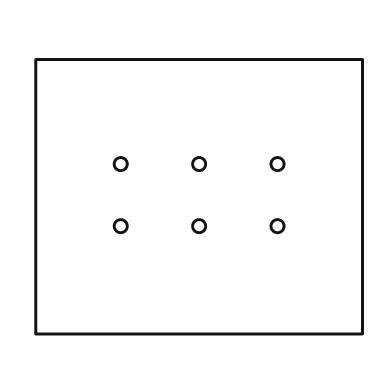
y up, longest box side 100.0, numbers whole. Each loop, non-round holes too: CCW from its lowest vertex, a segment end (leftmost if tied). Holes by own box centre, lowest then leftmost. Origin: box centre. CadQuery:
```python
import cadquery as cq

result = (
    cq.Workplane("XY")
    .moveTo(-50.0, -42.0)
    .lineTo(50.0, -42.0)
    .lineTo(50.0, 42.0)
    .lineTo(-50.0, 42.0)
    .close()
    .moveTo(-24.0, -9.0)
    .circle(2.0)
    .moveTo(0.0, -9.0)
    .circle(2.0)
    .moveTo(24.0, -9.0)
    .circle(2.0)
    .moveTo(-24.0, 10.0)
    .circle(2.0)
    .moveTo(0.0, 10.0)
    .circle(2.0)
    .moveTo(24.0, 10.0)
    .circle(2.0)
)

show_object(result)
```